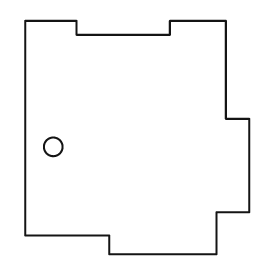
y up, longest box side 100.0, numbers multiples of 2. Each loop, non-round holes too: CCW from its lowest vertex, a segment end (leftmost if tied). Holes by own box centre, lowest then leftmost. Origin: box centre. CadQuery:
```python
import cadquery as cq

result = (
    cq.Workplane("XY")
    .moveTo(-12.0, -50.0)
    .lineTo(34.0, -50.0)
    .lineTo(34.0, -32.0)
    .lineTo(48.0, -32.0)
    .lineTo(48.0, 8.0)
    .lineTo(38.0, 8.0)
    .lineTo(38.0, 50.0)
    .lineTo(14.0, 50.0)
    .lineTo(14.0, 44.0)
    .lineTo(-26.0, 44.0)
    .lineTo(-26.0, 50.0)
    .lineTo(-48.0, 50.0)
    .lineTo(-48.0, -42.0)
    .lineTo(-12.0, -42.0)
    .close()
    .moveTo(-36.0, -4.0)
    .circle(4.0)
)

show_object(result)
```